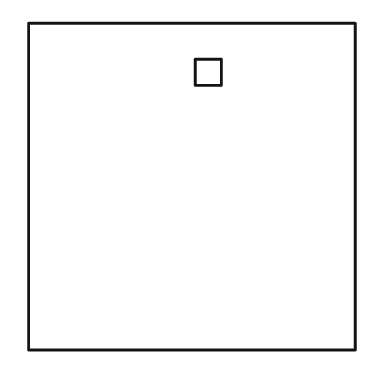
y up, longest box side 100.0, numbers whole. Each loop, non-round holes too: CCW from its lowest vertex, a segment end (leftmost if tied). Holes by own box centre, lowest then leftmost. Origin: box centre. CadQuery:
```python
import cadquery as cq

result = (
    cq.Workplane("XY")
    .moveTo(-50.0, -50.0)
    .lineTo(50.0, -50.0)
    .lineTo(50.0, 50.0)
    .lineTo(-50.0, 50.0)
    .close()
    .moveTo(1.0, 31.0)
    .lineTo(9.0, 31.0)
    .lineTo(9.0, 39.0)
    .lineTo(1.0, 39.0)
    .close()
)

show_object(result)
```